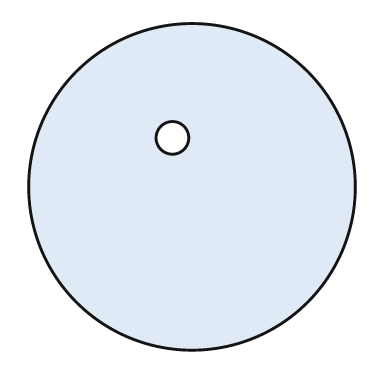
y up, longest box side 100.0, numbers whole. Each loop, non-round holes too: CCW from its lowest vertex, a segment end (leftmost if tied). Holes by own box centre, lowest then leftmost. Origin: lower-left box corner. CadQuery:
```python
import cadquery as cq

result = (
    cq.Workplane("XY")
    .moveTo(50.0, 50.0)
    .circle(50.0)
    .moveTo(44.0, 65.0)
    .circle(5.0)
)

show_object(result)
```